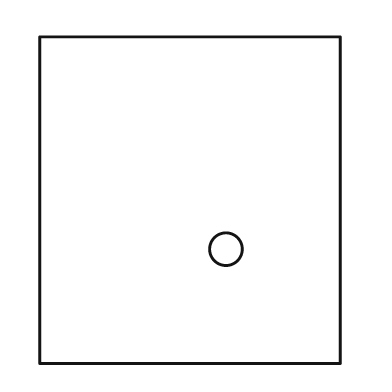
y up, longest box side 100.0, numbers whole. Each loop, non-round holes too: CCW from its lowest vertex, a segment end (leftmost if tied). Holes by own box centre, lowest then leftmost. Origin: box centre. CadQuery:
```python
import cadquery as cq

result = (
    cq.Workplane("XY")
    .moveTo(-46.0, -50.0)
    .lineTo(46.0, -50.0)
    .lineTo(46.0, 50.0)
    .lineTo(-46.0, 50.0)
    .close()
    .moveTo(11.0, -15.0)
    .circle(5.0)
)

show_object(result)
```